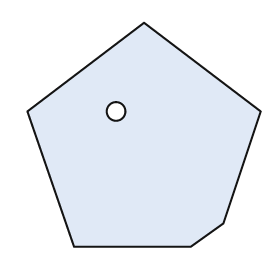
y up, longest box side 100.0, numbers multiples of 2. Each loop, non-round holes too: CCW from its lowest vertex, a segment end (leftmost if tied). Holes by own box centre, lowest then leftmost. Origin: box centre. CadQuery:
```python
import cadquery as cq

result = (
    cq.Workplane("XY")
    .moveTo(-30.0, -48.0)
    .lineTo(20.0, -48.0)
    .lineTo(34.0, -38.0)
    .lineTo(50.0, 10.0)
    .lineTo(0.0, 48.0)
    .lineTo(-50.0, 10.0)
    .close()
    .moveTo(-12.0, 10.0)
    .circle(4.0)
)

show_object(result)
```